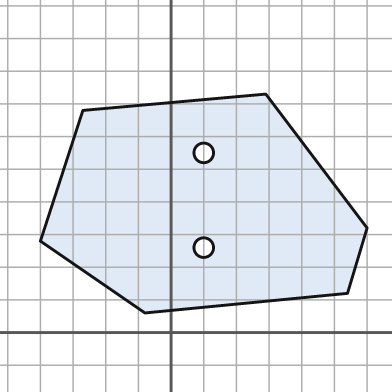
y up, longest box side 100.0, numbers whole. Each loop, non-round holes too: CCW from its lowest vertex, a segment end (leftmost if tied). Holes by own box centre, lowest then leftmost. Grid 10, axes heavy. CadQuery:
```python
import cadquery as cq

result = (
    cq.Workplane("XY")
    .moveTo(-8.0, 6.0)
    .lineTo(54.0, 12.0)
    .lineTo(60.0, 32.0)
    .lineTo(29.0, 73.0)
    .lineTo(-27.0, 68.0)
    .lineTo(-40.0, 28.0)
    .close()
    .moveTo(10.0, 26.0)
    .circle(3.0)
    .moveTo(10.0, 55.0)
    .circle(3.0)
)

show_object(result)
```